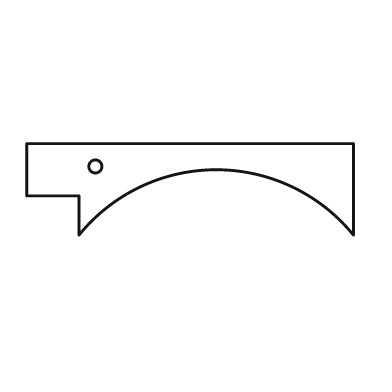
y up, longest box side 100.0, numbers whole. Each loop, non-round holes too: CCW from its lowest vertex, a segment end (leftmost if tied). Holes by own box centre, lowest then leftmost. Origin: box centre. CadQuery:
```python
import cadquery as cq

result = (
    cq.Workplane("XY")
    .moveTo(-34.0, -14.0)
    .threePointArc((8.0, 6.0), (50.0, -14.0))
    .lineTo(50.0, 14.0)
    .lineTo(-50.0, 14.0)
    .lineTo(-50.0, -2.0)
    .lineTo(-34.0, -2.0)
    .close()
    .moveTo(-29.0, 7.0)
    .circle(2.0)
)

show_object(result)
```